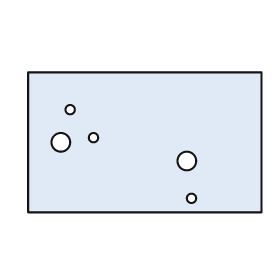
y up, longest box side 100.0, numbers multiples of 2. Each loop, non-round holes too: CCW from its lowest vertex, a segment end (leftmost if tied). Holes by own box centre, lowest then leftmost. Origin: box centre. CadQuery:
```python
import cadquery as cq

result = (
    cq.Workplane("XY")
    .moveTo(-50.0, -30.0)
    .lineTo(50.0, -30.0)
    .lineTo(50.0, 30.0)
    .lineTo(-50.0, 30.0)
    .close()
    .moveTo(20.0, -24.0)
    .circle(2.0)
    .moveTo(18.0, -8.0)
    .circle(4.0)
    .moveTo(-36.0, 0.0)
    .circle(4.0)
    .moveTo(-22.0, 2.0)
    .circle(2.0)
    .moveTo(-32.0, 14.0)
    .circle(2.0)
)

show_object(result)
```